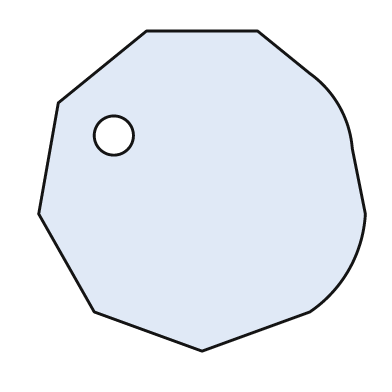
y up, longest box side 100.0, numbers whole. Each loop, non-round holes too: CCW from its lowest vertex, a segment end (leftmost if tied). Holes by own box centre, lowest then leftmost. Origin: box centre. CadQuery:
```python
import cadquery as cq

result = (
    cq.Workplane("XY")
    .moveTo(0.0, -49.0)
    .lineTo(33.0, -37.0)
    .threePointArc((45.0, -24.0), (50.0, -7.0))
    .lineTo(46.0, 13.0)
    .threePointArc((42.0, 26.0), (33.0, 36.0))
    .lineTo(17.0, 49.0)
    .lineTo(-17.0, 49.0)
    .lineTo(-44.0, 27.0)
    .lineTo(-50.0, -7.0)
    .lineTo(-33.0, -37.0)
    .close()
    .moveTo(-27.0, 17.0)
    .circle(6.0)
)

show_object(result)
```